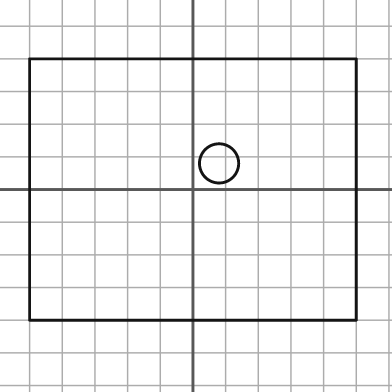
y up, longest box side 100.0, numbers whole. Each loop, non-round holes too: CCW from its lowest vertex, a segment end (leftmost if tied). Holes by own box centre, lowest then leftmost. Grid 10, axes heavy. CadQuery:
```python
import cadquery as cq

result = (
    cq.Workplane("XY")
    .moveTo(-50.0, -40.0)
    .lineTo(50.0, -40.0)
    .lineTo(50.0, 40.0)
    .lineTo(-50.0, 40.0)
    .close()
    .moveTo(8.0, 8.0)
    .circle(6.0)
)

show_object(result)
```